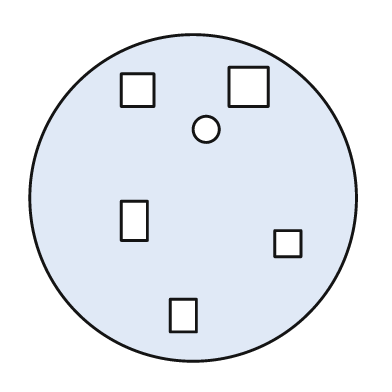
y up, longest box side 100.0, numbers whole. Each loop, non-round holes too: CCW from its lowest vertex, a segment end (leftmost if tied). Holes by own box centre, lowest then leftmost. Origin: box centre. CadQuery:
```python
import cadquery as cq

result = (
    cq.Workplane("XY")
    .moveTo(0.0, 0.0)
    .circle(50.0)
    .moveTo(-7.0, -41.0)
    .lineTo(1.0, -41.0)
    .lineTo(1.0, -31.0)
    .lineTo(-7.0, -31.0)
    .close()
    .moveTo(25.0, -18.0)
    .lineTo(33.0, -18.0)
    .lineTo(33.0, -10.0)
    .lineTo(25.0, -10.0)
    .close()
    .moveTo(-22.0, -13.0)
    .lineTo(-14.0, -13.0)
    .lineTo(-14.0, -1.0)
    .lineTo(-22.0, -1.0)
    .close()
    .moveTo(4.0, 21.0)
    .circle(4.0)
    .moveTo(-22.0, 28.0)
    .lineTo(-12.0, 28.0)
    .lineTo(-12.0, 38.0)
    .lineTo(-22.0, 38.0)
    .close()
    .moveTo(11.0, 28.0)
    .lineTo(23.0, 28.0)
    .lineTo(23.0, 40.0)
    .lineTo(11.0, 40.0)
    .close()
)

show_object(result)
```